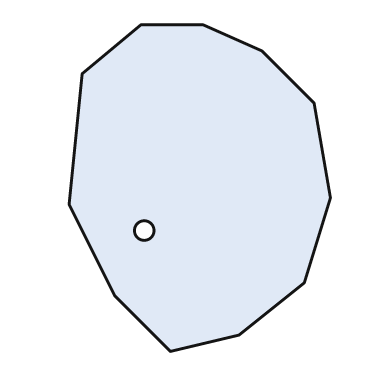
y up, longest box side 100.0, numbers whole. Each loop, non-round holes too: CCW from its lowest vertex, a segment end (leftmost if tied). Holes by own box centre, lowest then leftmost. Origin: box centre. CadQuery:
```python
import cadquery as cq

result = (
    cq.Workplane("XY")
    .moveTo(-9.0, -50.0)
    .lineTo(12.0, -45.0)
    .lineTo(32.0, -29.0)
    .lineTo(40.0, -3.0)
    .lineTo(35.0, 26.0)
    .lineTo(19.0, 42.0)
    .lineTo(1.0, 50.0)
    .lineTo(-18.0, 50.0)
    .lineTo(-36.0, 35.0)
    .lineTo(-40.0, -5.0)
    .lineTo(-26.0, -33.0)
    .close()
    .moveTo(-17.0, -13.0)
    .circle(3.0)
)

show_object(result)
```